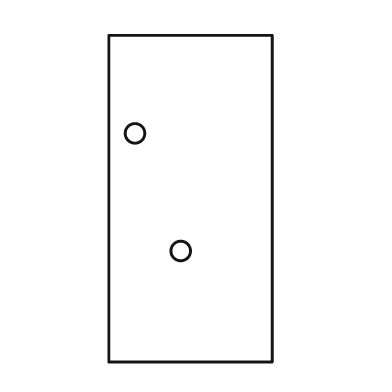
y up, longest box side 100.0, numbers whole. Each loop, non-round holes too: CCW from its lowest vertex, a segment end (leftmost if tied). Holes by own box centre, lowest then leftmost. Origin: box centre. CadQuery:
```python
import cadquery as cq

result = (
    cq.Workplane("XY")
    .moveTo(-25.0, -50.0)
    .lineTo(25.0, -50.0)
    .lineTo(25.0, 50.0)
    .lineTo(-25.0, 50.0)
    .close()
    .moveTo(-3.0, -16.0)
    .circle(3.0)
    .moveTo(-17.0, 20.0)
    .circle(3.0)
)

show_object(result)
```